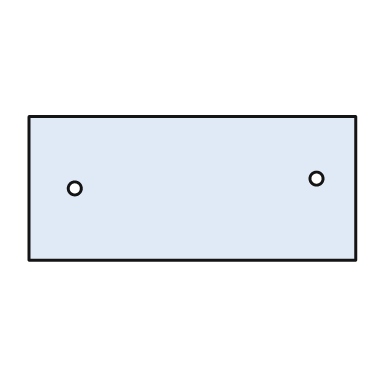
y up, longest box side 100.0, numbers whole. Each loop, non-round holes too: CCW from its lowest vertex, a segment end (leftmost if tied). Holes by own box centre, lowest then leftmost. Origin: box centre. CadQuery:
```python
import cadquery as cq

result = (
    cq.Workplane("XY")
    .moveTo(-50.0, -22.0)
    .lineTo(50.0, -22.0)
    .lineTo(50.0, 22.0)
    .lineTo(-50.0, 22.0)
    .close()
    .moveTo(-36.0, 0.0)
    .circle(2.0)
    .moveTo(38.0, 3.0)
    .circle(2.0)
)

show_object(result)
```